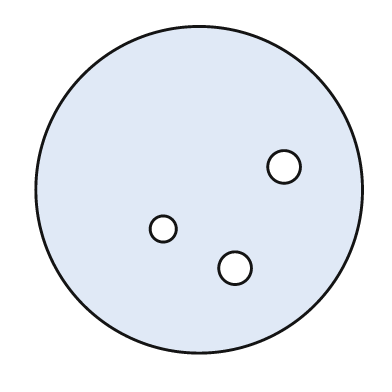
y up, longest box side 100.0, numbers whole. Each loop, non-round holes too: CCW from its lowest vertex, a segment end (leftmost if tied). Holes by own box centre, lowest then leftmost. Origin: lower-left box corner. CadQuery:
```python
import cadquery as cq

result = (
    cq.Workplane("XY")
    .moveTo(50.0, 50.0)
    .circle(50.0)
    .moveTo(61.0, 26.0)
    .circle(5.0)
    .moveTo(39.0, 38.0)
    .circle(4.0)
    .moveTo(76.0, 57.0)
    .circle(5.0)
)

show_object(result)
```